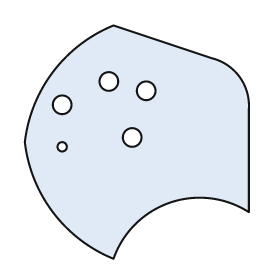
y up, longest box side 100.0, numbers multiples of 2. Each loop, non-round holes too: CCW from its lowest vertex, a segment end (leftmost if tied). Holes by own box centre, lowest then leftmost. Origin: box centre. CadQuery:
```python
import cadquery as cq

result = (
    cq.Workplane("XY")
    .moveTo(-10.0, -50.0)
    .threePointArc((14.0, -26.0), (48.0, -30.0))
    .lineTo(48.0, 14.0)
    .threePointArc((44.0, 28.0), (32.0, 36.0))
    .lineTo(-10.0, 50.0)
    .threePointArc((-36.0, 30.0), (-48.0, 0.0))
    .threePointArc((-36.0, -30.0), (-10.0, -50.0))
    .close()
    .moveTo(-32.0, -2.0)
    .circle(2.0)
    .moveTo(-2.0, 2.0)
    .circle(4.0)
    .moveTo(-32.0, 16.0)
    .circle(4.0)
    .moveTo(4.0, 22.0)
    .circle(4.0)
    .moveTo(-12.0, 26.0)
    .circle(4.0)
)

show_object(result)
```